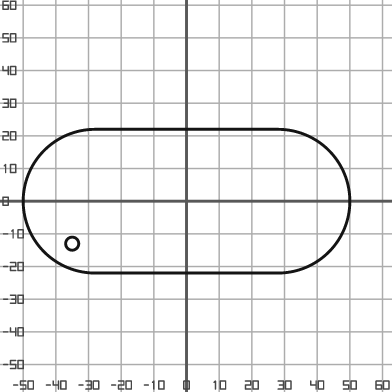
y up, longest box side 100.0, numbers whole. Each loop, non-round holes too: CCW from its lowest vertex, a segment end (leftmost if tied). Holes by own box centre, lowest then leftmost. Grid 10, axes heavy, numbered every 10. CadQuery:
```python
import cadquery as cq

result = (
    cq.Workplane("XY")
    .moveTo(-28.0, -22.0)
    .lineTo(28.0, -22.0)
    .threePointArc((50.0, 0.0), (28.0, 22.0))
    .lineTo(-28.0, 22.0)
    .threePointArc((-50.0, 0.0), (-28.0, -22.0))
    .close()
    .moveTo(-35.0, -13.0)
    .circle(2.0)
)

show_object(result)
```